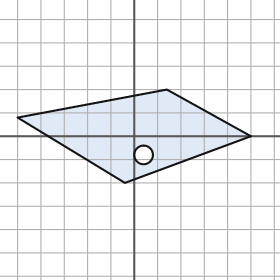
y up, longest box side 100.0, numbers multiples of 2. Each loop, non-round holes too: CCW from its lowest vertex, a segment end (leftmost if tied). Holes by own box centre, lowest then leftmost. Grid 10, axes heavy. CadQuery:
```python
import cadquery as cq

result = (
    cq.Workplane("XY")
    .moveTo(-4.0, -20.0)
    .lineTo(50.0, 0.0)
    .lineTo(14.0, 20.0)
    .lineTo(-50.0, 8.0)
    .close()
    .moveTo(4.0, -8.0)
    .circle(4.0)
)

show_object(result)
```